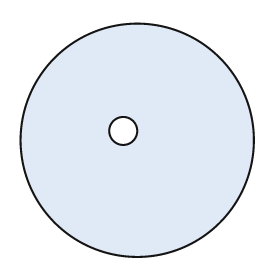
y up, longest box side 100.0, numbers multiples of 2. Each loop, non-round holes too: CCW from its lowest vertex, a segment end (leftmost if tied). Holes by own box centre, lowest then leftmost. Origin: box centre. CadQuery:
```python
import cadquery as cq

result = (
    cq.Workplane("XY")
    .moveTo(0.0, 0.0)
    .circle(50.0)
    .moveTo(-6.0, 4.0)
    .circle(6.0)
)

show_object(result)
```